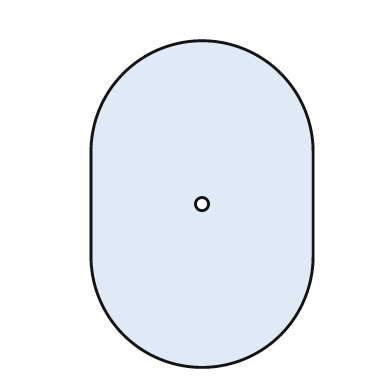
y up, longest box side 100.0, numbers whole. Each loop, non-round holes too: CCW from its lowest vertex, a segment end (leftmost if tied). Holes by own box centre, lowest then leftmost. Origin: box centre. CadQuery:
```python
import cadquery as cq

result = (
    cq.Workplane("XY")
    .moveTo(-34.0, -16.0)
    .threePointArc((0.0, -50.0), (34.0, -16.0))
    .lineTo(34.0, 16.0)
    .threePointArc((0.0, 50.0), (-34.0, 16.0))
    .close()
    .moveTo(0.0, 0.0)
    .circle(2.0)
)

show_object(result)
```